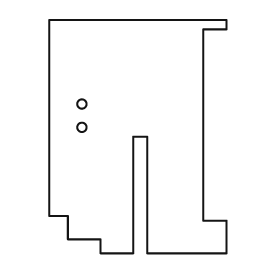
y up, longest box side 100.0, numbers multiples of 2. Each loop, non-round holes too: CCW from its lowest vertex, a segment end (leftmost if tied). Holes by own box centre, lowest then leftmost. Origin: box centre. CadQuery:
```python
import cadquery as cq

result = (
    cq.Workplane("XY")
    .moveTo(-16.0, -50.0)
    .lineTo(-2.0, -50.0)
    .lineTo(-2.0, 0.0)
    .lineTo(4.0, 0.0)
    .lineTo(4.0, -50.0)
    .lineTo(38.0, -50.0)
    .lineTo(38.0, -36.0)
    .lineTo(28.0, -36.0)
    .lineTo(28.0, 46.0)
    .lineTo(38.0, 46.0)
    .lineTo(38.0, 50.0)
    .lineTo(-38.0, 50.0)
    .lineTo(-38.0, -34.0)
    .lineTo(-30.0, -34.0)
    .lineTo(-30.0, -44.0)
    .lineTo(-16.0, -44.0)
    .close()
    .moveTo(-24.0, 4.0)
    .circle(2.0)
    .moveTo(-24.0, 14.0)
    .circle(2.0)
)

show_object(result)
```